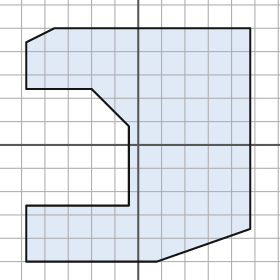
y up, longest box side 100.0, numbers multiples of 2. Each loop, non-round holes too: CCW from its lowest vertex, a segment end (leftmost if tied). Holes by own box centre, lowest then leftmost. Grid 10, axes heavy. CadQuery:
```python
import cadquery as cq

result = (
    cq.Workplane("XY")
    .moveTo(-48.0, -50.0)
    .lineTo(8.0, -50.0)
    .lineTo(48.0, -36.0)
    .lineTo(48.0, 50.0)
    .lineTo(-36.0, 50.0)
    .lineTo(-48.0, 44.0)
    .lineTo(-48.0, 24.0)
    .lineTo(-20.0, 24.0)
    .lineTo(-4.0, 8.0)
    .lineTo(-4.0, -26.0)
    .lineTo(-48.0, -26.0)
    .close()
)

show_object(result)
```